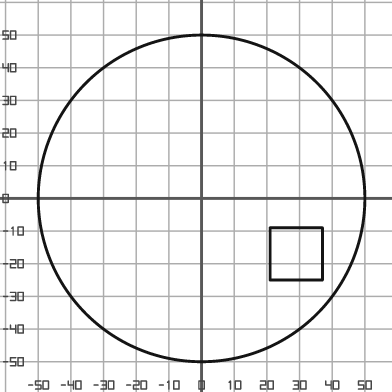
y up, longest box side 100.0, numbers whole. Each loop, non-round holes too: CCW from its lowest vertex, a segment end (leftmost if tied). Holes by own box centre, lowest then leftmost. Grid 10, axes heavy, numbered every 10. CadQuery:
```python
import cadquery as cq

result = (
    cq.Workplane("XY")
    .moveTo(0.0, 0.0)
    .circle(50.0)
    .moveTo(21.0, -25.0)
    .lineTo(37.0, -25.0)
    .lineTo(37.0, -9.0)
    .lineTo(21.0, -9.0)
    .close()
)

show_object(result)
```